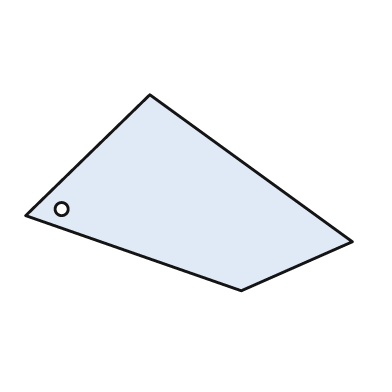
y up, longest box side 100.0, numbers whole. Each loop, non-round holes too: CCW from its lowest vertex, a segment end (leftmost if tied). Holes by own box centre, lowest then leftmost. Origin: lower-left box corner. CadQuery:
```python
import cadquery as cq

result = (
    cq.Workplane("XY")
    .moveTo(66.0, 0.0)
    .lineTo(100.0, 15.0)
    .lineTo(38.0, 60.0)
    .lineTo(0.0, 23.0)
    .close()
    .moveTo(11.0, 25.0)
    .circle(2.0)
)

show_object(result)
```